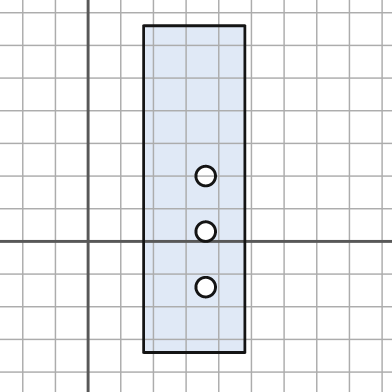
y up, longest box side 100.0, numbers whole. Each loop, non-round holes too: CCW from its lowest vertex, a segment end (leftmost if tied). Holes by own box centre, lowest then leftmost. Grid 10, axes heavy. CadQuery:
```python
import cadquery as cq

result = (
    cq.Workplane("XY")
    .moveTo(17.0, -34.0)
    .lineTo(48.0, -34.0)
    .lineTo(48.0, 66.0)
    .lineTo(17.0, 66.0)
    .close()
    .moveTo(36.0, -14.0)
    .circle(3.0)
    .moveTo(36.0, 3.0)
    .circle(3.0)
    .moveTo(36.0, 20.0)
    .circle(3.0)
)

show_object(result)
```